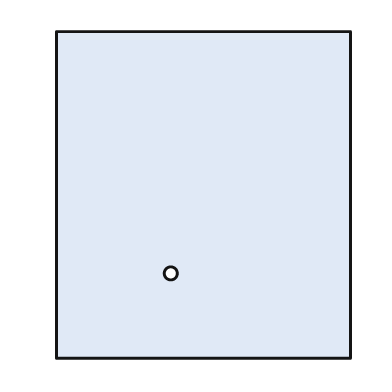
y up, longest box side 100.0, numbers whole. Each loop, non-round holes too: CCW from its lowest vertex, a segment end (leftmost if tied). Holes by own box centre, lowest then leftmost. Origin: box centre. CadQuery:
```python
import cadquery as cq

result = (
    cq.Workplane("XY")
    .moveTo(-45.0, -50.0)
    .lineTo(45.0, -50.0)
    .lineTo(45.0, 50.0)
    .lineTo(-45.0, 50.0)
    .close()
    .moveTo(-10.0, -24.0)
    .circle(2.0)
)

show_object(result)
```